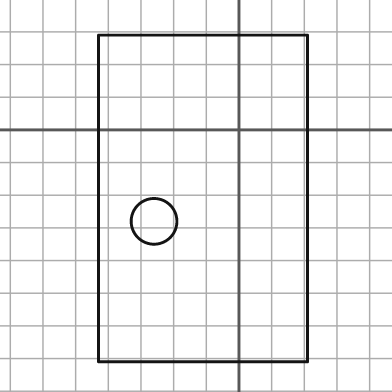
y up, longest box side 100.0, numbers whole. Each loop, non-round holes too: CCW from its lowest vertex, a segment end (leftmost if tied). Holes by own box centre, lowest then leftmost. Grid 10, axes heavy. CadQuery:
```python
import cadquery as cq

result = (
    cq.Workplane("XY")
    .moveTo(-43.0, -71.0)
    .lineTo(21.0, -71.0)
    .lineTo(21.0, 29.0)
    .lineTo(-43.0, 29.0)
    .close()
    .moveTo(-26.0, -28.0)
    .circle(7.0)
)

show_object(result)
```